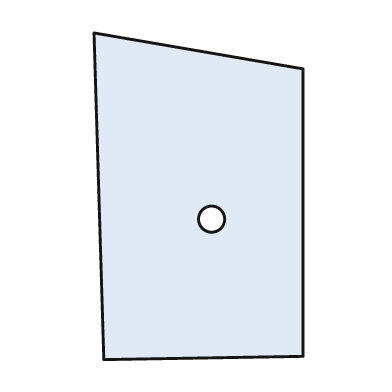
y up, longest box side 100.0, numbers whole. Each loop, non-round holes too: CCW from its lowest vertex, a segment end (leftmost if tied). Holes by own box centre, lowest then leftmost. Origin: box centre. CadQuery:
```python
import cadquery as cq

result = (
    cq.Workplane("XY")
    .moveTo(-29.0, -50.0)
    .lineTo(32.0, -49.0)
    .lineTo(32.0, 39.0)
    .lineTo(-32.0, 50.0)
    .close()
    .moveTo(4.0, -7.0)
    .circle(4.0)
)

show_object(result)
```